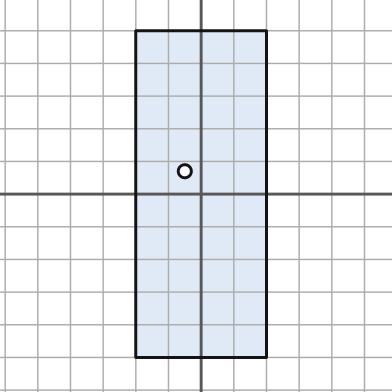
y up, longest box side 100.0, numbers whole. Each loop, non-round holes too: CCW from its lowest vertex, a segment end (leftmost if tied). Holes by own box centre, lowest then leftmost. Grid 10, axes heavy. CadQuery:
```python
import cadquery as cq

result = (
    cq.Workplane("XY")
    .moveTo(-20.0, -50.0)
    .lineTo(20.0, -50.0)
    .lineTo(20.0, 50.0)
    .lineTo(-20.0, 50.0)
    .close()
    .moveTo(-5.0, 7.0)
    .circle(2.0)
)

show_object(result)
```